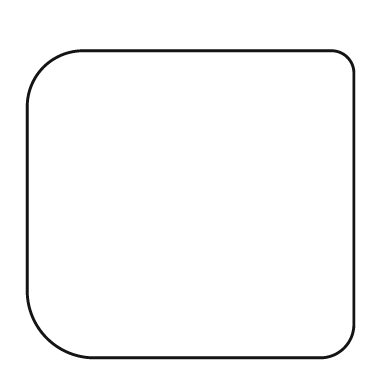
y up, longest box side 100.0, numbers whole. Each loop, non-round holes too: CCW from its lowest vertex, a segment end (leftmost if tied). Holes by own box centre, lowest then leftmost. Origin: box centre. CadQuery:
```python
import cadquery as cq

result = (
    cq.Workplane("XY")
    .moveTo(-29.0, -47.0)
    .lineTo(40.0, -47.0)
    .threePointArc((47.0, -44.0), (50.0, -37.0))
    .lineTo(50.0, 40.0)
    .threePointArc((48.0, 45.0), (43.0, 47.0))
    .lineTo(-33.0, 47.0)
    .threePointArc((-45.0, 42.0), (-50.0, 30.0))
    .lineTo(-50.0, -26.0)
    .threePointArc((-44.0, -41.0), (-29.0, -47.0))
    .close()
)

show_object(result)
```